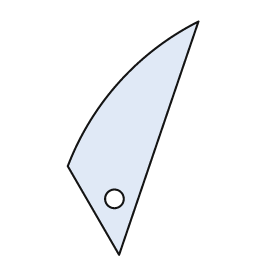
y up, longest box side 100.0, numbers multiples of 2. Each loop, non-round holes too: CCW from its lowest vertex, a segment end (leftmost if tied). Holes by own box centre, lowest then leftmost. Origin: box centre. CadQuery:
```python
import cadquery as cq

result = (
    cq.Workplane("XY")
    .moveTo(-6.0, -50.0)
    .lineTo(28.0, 50.0)
    .threePointArc((-6.0, 24.0), (-28.0, -12.0))
    .close()
    .moveTo(-8.0, -26.0)
    .circle(4.0)
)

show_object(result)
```